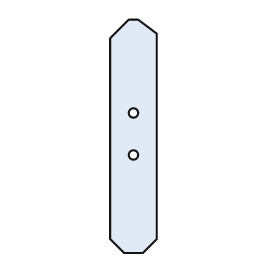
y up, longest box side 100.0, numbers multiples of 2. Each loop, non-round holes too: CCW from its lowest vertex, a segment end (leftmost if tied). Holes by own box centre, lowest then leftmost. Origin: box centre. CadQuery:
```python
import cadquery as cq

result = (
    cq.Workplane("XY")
    .moveTo(-4.0, -50.0)
    .lineTo(4.0, -50.0)
    .lineTo(10.0, -44.0)
    .lineTo(10.0, 44.0)
    .lineTo(2.0, 50.0)
    .lineTo(-2.0, 50.0)
    .lineTo(-10.0, 42.0)
    .lineTo(-10.0, -44.0)
    .close()
    .moveTo(0.0, -8.0)
    .circle(2.0)
    .moveTo(0.0, 10.0)
    .circle(2.0)
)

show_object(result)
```